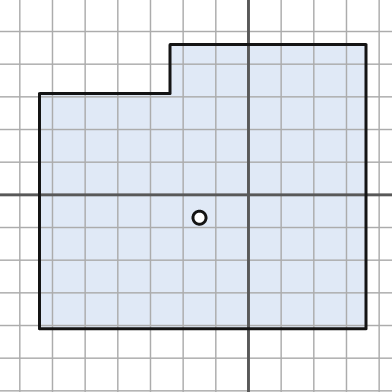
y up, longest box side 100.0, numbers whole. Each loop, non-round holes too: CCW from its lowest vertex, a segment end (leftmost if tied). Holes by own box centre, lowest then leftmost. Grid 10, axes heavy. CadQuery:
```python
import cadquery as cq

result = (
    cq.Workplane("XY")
    .moveTo(-64.0, -41.0)
    .lineTo(36.0, -41.0)
    .lineTo(36.0, 46.0)
    .lineTo(-24.0, 46.0)
    .lineTo(-24.0, 31.0)
    .lineTo(-64.0, 31.0)
    .close()
    .moveTo(-15.0, -7.0)
    .circle(2.0)
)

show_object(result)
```